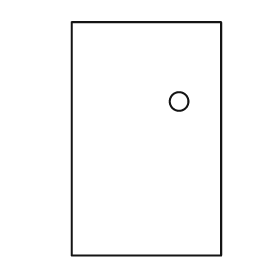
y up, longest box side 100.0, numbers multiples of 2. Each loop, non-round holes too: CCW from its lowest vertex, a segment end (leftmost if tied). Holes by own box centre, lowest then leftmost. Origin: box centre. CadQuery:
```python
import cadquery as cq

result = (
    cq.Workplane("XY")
    .moveTo(-32.0, -50.0)
    .lineTo(32.0, -50.0)
    .lineTo(32.0, 50.0)
    .lineTo(-32.0, 50.0)
    .close()
    .moveTo(14.0, 16.0)
    .circle(4.0)
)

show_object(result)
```